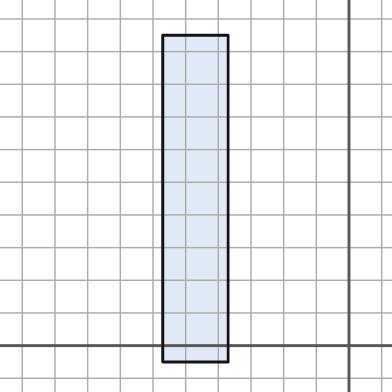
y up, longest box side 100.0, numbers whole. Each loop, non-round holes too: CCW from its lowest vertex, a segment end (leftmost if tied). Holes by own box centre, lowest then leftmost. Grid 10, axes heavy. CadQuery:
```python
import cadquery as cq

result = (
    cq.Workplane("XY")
    .moveTo(-57.0, -5.0)
    .lineTo(-37.0, -5.0)
    .lineTo(-37.0, 95.0)
    .lineTo(-57.0, 95.0)
    .close()
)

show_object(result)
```